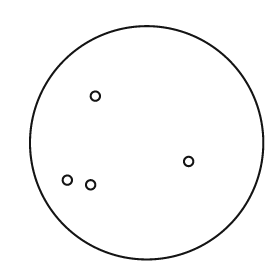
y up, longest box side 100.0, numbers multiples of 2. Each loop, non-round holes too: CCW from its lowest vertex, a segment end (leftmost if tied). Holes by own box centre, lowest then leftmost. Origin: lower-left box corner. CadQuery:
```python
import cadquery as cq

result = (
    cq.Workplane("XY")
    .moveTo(50.0, 50.0)
    .circle(50.0)
    .moveTo(26.0, 32.0)
    .circle(2.0)
    .moveTo(16.0, 34.0)
    .circle(2.0)
    .moveTo(68.0, 42.0)
    .circle(2.0)
    .moveTo(28.0, 70.0)
    .circle(2.0)
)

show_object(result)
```